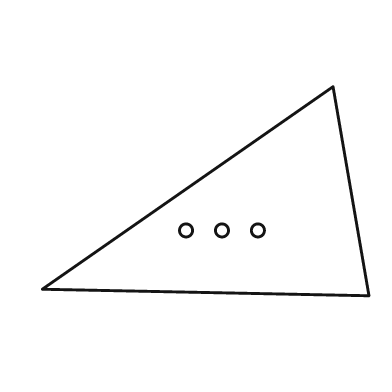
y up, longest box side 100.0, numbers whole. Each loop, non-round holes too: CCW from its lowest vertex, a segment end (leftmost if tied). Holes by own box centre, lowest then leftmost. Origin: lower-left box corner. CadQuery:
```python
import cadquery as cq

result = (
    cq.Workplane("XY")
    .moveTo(100.0, 0.0)
    .lineTo(89.0, 64.0)
    .lineTo(0.0, 2.0)
    .close()
    .moveTo(44.0, 20.0)
    .circle(2.0)
    .moveTo(55.0, 20.0)
    .circle(2.0)
    .moveTo(66.0, 20.0)
    .circle(2.0)
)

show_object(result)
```